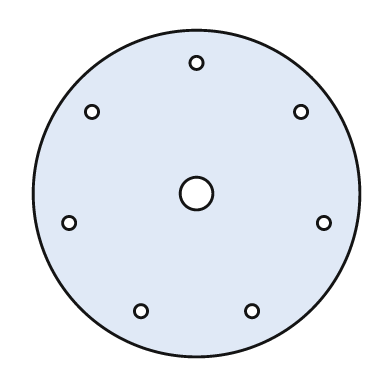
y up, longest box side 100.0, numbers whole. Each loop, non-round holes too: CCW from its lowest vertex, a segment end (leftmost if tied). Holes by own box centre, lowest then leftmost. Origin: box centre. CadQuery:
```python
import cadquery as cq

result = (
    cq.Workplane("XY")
    .moveTo(0.0, 0.0)
    .circle(50.0)
    .moveTo(-17.0, -36.0)
    .circle(2.0)
    .moveTo(17.0, -36.0)
    .circle(2.0)
    .moveTo(-39.0, -9.0)
    .circle(2.0)
    .moveTo(39.0, -9.0)
    .circle(2.0)
    .moveTo(0.0, 0.0)
    .circle(5.0)
    .moveTo(-32.0, 25.0)
    .circle(2.0)
    .moveTo(32.0, 25.0)
    .circle(2.0)
    .moveTo(0.0, 40.0)
    .circle(2.0)
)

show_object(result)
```